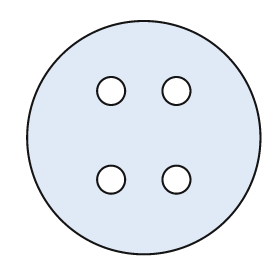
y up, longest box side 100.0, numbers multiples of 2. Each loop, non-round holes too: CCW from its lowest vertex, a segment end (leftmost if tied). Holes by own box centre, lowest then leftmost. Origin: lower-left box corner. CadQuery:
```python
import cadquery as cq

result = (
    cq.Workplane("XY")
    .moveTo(50.0, 50.0)
    .circle(50.0)
    .moveTo(36.0, 32.0)
    .circle(6.0)
    .moveTo(64.0, 32.0)
    .circle(6.0)
    .moveTo(36.0, 70.0)
    .circle(6.0)
    .moveTo(64.0, 70.0)
    .circle(6.0)
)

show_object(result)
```